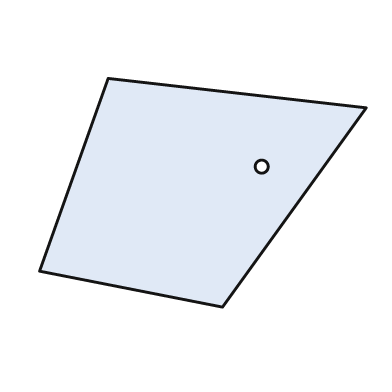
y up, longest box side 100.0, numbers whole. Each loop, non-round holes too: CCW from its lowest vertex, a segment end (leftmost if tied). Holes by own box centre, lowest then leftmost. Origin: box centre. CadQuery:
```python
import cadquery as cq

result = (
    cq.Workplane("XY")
    .moveTo(6.0, -35.0)
    .lineTo(50.0, 26.0)
    .lineTo(-29.0, 35.0)
    .lineTo(-50.0, -24.0)
    .close()
    .moveTo(18.0, 8.0)
    .circle(2.0)
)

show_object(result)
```